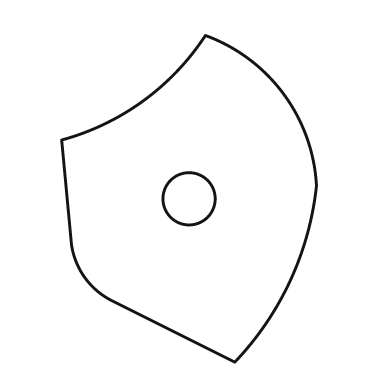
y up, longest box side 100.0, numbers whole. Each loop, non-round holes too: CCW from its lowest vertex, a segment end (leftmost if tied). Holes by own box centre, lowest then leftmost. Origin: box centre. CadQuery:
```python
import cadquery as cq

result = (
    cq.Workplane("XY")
    .moveTo(14.0, -50.0)
    .threePointArc((31.0, -25.0), (39.0, 4.0))
    .threePointArc((29.0, 32.0), (5.0, 50.0))
    .threePointArc((-14.0, 30.0), (-39.0, 18.0))
    .lineTo(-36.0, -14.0)
    .threePointArc((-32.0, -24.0), (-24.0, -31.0))
    .close()
    .moveTo(0.0, 0.0)
    .circle(8.0)
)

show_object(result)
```